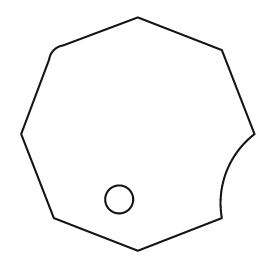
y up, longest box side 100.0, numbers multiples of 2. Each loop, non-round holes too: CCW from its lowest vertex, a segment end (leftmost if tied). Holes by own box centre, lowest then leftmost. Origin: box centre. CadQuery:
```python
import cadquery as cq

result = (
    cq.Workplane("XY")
    .moveTo(0.0, -50.0)
    .lineTo(36.0, -36.0)
    .threePointArc((38.0, -16.0), (50.0, 0.0))
    .lineTo(36.0, 36.0)
    .lineTo(0.0, 50.0)
    .lineTo(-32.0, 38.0)
    .threePointArc((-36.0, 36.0), (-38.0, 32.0))
    .lineTo(-50.0, 0.0)
    .lineTo(-36.0, -36.0)
    .close()
    .moveTo(-8.0, -28.0)
    .circle(6.0)
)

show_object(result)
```